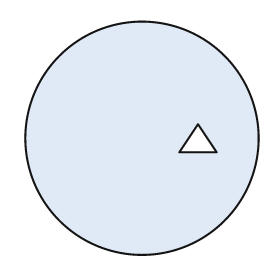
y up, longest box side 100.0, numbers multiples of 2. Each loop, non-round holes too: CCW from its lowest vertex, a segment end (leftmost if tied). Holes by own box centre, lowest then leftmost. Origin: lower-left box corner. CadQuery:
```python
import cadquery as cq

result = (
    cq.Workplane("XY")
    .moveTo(50.0, 50.0)
    .circle(50.0)
    .moveTo(66.0, 44.0)
    .lineTo(82.0, 44.0)
    .lineTo(74.0, 56.0)
    .close()
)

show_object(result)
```